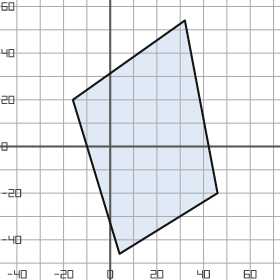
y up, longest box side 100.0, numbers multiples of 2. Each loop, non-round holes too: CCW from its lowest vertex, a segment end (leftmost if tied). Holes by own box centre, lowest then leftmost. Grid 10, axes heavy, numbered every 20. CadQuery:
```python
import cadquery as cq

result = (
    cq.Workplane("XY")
    .moveTo(4.0, -46.0)
    .lineTo(46.0, -20.0)
    .lineTo(32.0, 54.0)
    .lineTo(-16.0, 20.0)
    .close()
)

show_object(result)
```